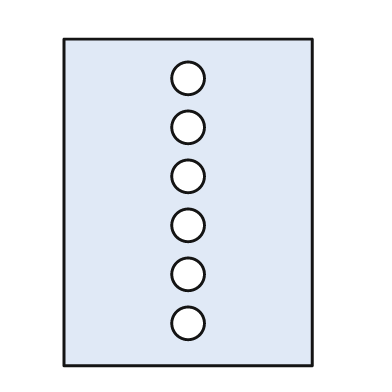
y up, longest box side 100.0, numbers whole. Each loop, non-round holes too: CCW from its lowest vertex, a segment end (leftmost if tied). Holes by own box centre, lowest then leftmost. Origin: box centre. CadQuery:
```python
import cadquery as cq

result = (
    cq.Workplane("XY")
    .moveTo(-38.0, -50.0)
    .lineTo(38.0, -50.0)
    .lineTo(38.0, 50.0)
    .lineTo(-38.0, 50.0)
    .close()
    .moveTo(0.0, -37.0)
    .circle(5.0)
    .moveTo(0.0, -22.0)
    .circle(5.0)
    .moveTo(0.0, -7.0)
    .circle(5.0)
    .moveTo(0.0, 8.0)
    .circle(5.0)
    .moveTo(0.0, 23.0)
    .circle(5.0)
    .moveTo(0.0, 38.0)
    .circle(5.0)
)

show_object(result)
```